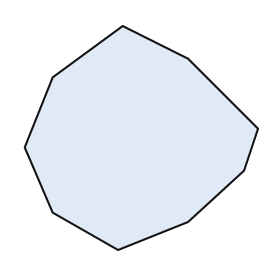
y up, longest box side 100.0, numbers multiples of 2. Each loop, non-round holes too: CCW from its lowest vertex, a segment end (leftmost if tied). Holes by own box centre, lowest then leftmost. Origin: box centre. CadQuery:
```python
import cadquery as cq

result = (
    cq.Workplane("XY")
    .moveTo(-10.0, -48.0)
    .lineTo(20.0, -36.0)
    .lineTo(44.0, -14.0)
    .lineTo(50.0, 4.0)
    .lineTo(20.0, 34.0)
    .lineTo(-8.0, 48.0)
    .lineTo(-38.0, 26.0)
    .lineTo(-50.0, -4.0)
    .lineTo(-38.0, -32.0)
    .close()
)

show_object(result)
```